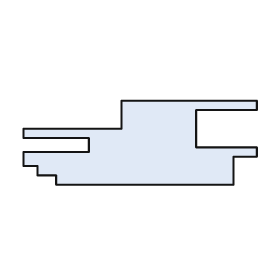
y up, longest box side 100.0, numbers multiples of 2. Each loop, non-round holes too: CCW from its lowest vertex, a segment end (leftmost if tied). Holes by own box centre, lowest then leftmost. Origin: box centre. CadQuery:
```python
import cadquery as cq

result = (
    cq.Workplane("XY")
    .moveTo(-36.0, -18.0)
    .lineTo(40.0, -18.0)
    .lineTo(40.0, -6.0)
    .lineTo(50.0, -6.0)
    .lineTo(50.0, -2.0)
    .lineTo(24.0, -2.0)
    .lineTo(24.0, 14.0)
    .lineTo(50.0, 14.0)
    .lineTo(50.0, 18.0)
    .lineTo(-8.0, 18.0)
    .lineTo(-8.0, 6.0)
    .lineTo(-50.0, 6.0)
    .lineTo(-50.0, 2.0)
    .lineTo(-22.0, 2.0)
    .lineTo(-22.0, -4.0)
    .lineTo(-50.0, -4.0)
    .lineTo(-50.0, -10.0)
    .lineTo(-44.0, -10.0)
    .lineTo(-44.0, -14.0)
    .lineTo(-36.0, -14.0)
    .close()
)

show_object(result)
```